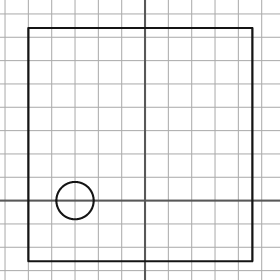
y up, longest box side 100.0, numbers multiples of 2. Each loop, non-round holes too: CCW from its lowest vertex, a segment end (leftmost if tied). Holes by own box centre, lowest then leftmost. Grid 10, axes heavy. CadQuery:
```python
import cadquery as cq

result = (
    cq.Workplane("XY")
    .moveTo(-50.0, -26.0)
    .lineTo(46.0, -26.0)
    .lineTo(46.0, 74.0)
    .lineTo(-50.0, 74.0)
    .close()
    .moveTo(-30.0, 0.0)
    .circle(8.0)
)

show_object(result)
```